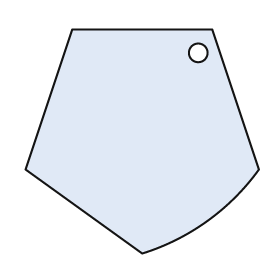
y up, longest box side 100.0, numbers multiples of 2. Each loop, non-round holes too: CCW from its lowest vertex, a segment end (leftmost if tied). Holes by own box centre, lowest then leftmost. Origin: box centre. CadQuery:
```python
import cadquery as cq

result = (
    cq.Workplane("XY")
    .moveTo(0.0, -48.0)
    .threePointArc((28.0, -34.0), (50.0, -12.0))
    .lineTo(30.0, 48.0)
    .lineTo(-30.0, 48.0)
    .lineTo(-50.0, -12.0)
    .close()
    .moveTo(24.0, 38.0)
    .circle(4.0)
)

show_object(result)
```